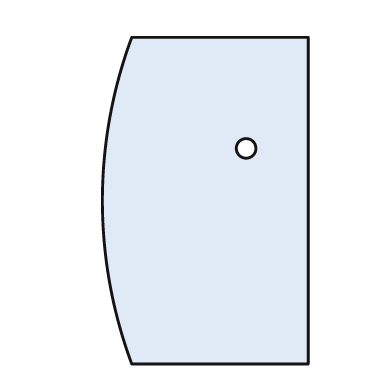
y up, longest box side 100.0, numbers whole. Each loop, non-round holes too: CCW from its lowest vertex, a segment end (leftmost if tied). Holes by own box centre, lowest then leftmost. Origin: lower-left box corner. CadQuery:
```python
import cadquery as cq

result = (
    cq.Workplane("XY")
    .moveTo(9.0, 0.0)
    .lineTo(63.0, 0.0)
    .lineTo(63.0, 100.0)
    .lineTo(9.0, 100.0)
    .threePointArc((0.0, 50.0), (9.0, 0.0))
    .close()
    .moveTo(44.0, 66.0)
    .circle(3.0)
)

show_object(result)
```